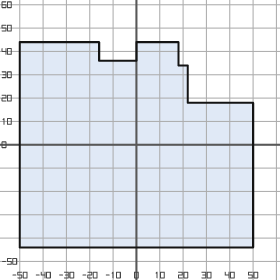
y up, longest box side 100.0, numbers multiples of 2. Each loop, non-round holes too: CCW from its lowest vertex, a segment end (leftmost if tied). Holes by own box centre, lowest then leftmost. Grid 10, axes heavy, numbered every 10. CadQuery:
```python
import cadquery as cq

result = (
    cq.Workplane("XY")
    .moveTo(-50.0, -44.0)
    .lineTo(50.0, -44.0)
    .lineTo(50.0, 18.0)
    .lineTo(22.0, 18.0)
    .lineTo(22.0, 34.0)
    .lineTo(18.0, 34.0)
    .lineTo(18.0, 44.0)
    .lineTo(0.0, 44.0)
    .lineTo(0.0, 36.0)
    .lineTo(-16.0, 36.0)
    .lineTo(-16.0, 44.0)
    .lineTo(-50.0, 44.0)
    .close()
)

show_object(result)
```